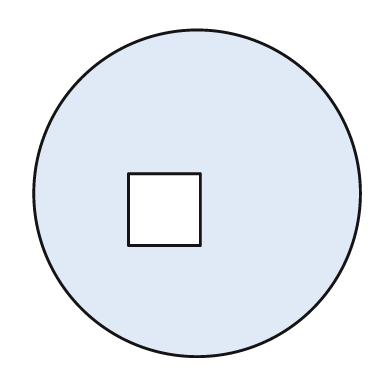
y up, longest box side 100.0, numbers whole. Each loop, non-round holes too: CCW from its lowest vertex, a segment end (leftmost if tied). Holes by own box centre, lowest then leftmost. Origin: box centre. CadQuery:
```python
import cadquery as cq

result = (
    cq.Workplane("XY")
    .moveTo(0.0, 0.0)
    .circle(50.0)
    .moveTo(-21.0, -16.0)
    .lineTo(1.0, -16.0)
    .lineTo(1.0, 6.0)
    .lineTo(-21.0, 6.0)
    .close()
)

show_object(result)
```